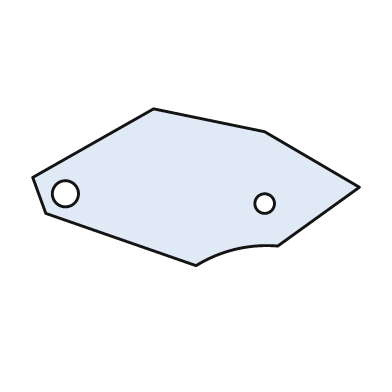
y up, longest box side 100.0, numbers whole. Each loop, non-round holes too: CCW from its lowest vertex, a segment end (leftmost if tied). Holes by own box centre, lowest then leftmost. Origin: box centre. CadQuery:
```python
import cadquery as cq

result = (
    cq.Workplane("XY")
    .moveTo(0.0, -24.0)
    .threePointArc((12.0, -19.0), (25.0, -18.0))
    .lineTo(50.0, 0.0)
    .lineTo(21.0, 17.0)
    .lineTo(-13.0, 24.0)
    .lineTo(-50.0, 3.0)
    .lineTo(-46.0, -8.0)
    .close()
    .moveTo(21.0, -5.0)
    .circle(3.0)
    .moveTo(-40.0, -2.0)
    .circle(4.0)
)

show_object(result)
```